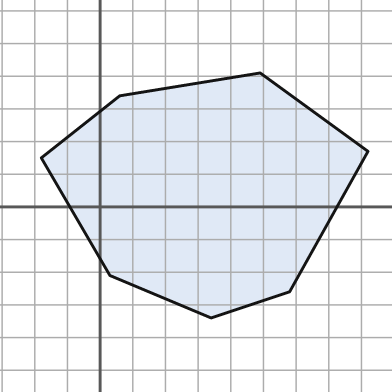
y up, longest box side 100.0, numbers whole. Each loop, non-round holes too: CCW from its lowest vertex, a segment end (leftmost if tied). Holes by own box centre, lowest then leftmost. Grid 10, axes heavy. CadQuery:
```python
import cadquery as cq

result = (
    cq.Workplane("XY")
    .moveTo(34.0, -34.0)
    .lineTo(58.0, -26.0)
    .lineTo(82.0, 17.0)
    .lineTo(49.0, 41.0)
    .lineTo(6.0, 34.0)
    .lineTo(-18.0, 15.0)
    .lineTo(3.0, -21.0)
    .close()
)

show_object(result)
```